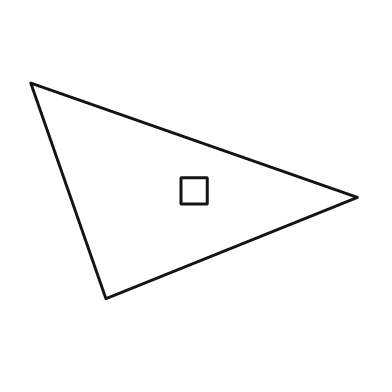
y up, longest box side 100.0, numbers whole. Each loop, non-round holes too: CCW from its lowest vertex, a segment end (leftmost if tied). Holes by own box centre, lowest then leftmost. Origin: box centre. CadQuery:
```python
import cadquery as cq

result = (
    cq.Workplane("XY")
    .moveTo(-27.0, -33.0)
    .lineTo(50.0, -2.0)
    .lineTo(-50.0, 33.0)
    .close()
    .moveTo(-4.0, -4.0)
    .lineTo(4.0, -4.0)
    .lineTo(4.0, 4.0)
    .lineTo(-4.0, 4.0)
    .close()
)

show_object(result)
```